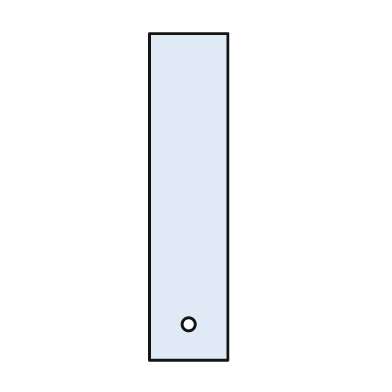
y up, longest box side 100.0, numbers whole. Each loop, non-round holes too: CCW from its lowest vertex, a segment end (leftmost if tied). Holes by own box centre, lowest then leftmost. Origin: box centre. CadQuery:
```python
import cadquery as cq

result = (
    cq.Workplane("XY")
    .moveTo(-12.0, -50.0)
    .lineTo(12.0, -50.0)
    .lineTo(12.0, 50.0)
    .lineTo(-12.0, 50.0)
    .close()
    .moveTo(0.0, -39.0)
    .circle(2.0)
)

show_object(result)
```